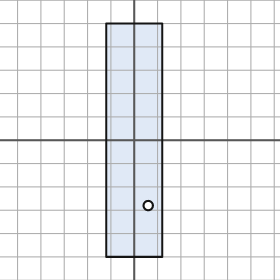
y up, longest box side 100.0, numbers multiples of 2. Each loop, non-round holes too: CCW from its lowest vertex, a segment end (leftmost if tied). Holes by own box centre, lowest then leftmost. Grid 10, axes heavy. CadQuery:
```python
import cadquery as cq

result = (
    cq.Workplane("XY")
    .moveTo(-12.0, -50.0)
    .lineTo(12.0, -50.0)
    .lineTo(12.0, 50.0)
    .lineTo(-12.0, 50.0)
    .close()
    .moveTo(6.0, -28.0)
    .circle(2.0)
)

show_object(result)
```